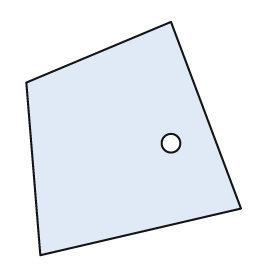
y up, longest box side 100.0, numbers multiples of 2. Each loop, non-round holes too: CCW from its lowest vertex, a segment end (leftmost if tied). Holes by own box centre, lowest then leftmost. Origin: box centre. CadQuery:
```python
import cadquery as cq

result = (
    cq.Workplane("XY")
    .moveTo(-40.0, -50.0)
    .lineTo(46.0, -30.0)
    .lineTo(16.0, 50.0)
    .lineTo(-46.0, 24.0)
    .close()
    .moveTo(16.0, -2.0)
    .circle(4.0)
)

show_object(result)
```